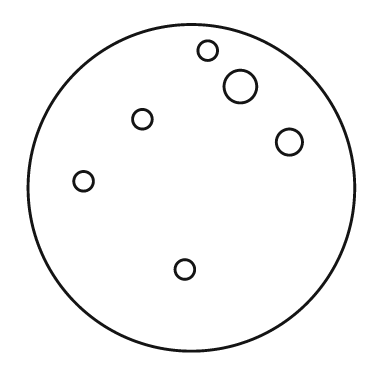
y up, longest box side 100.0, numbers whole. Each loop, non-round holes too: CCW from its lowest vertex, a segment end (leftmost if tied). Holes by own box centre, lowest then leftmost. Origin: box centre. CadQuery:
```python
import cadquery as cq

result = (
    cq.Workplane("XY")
    .moveTo(0.0, 0.0)
    .circle(50.0)
    .moveTo(-2.0, -25.0)
    .circle(3.0)
    .moveTo(-33.0, 2.0)
    .circle(3.0)
    .moveTo(30.0, 14.0)
    .circle(4.0)
    .moveTo(-15.0, 21.0)
    .circle(3.0)
    .moveTo(15.0, 31.0)
    .circle(5.0)
    .moveTo(5.0, 42.0)
    .circle(3.0)
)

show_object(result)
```